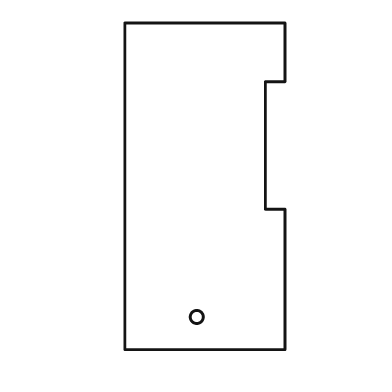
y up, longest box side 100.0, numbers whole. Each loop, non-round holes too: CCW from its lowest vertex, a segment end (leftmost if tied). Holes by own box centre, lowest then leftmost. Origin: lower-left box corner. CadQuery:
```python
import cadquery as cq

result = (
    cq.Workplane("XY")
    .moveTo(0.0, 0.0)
    .lineTo(49.0, 0.0)
    .lineTo(49.0, 43.0)
    .lineTo(43.0, 43.0)
    .lineTo(43.0, 82.0)
    .lineTo(49.0, 82.0)
    .lineTo(49.0, 100.0)
    .lineTo(0.0, 100.0)
    .close()
    .moveTo(22.0, 10.0)
    .circle(2.0)
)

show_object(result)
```